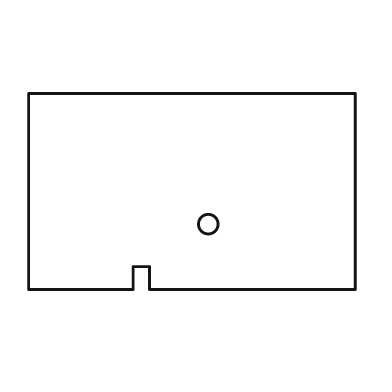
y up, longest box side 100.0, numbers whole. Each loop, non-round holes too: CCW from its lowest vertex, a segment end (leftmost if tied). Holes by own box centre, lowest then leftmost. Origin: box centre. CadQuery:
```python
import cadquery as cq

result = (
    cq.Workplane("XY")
    .moveTo(-50.0, -30.0)
    .lineTo(-18.0, -30.0)
    .lineTo(-18.0, -23.0)
    .lineTo(-13.0, -23.0)
    .lineTo(-13.0, -30.0)
    .lineTo(50.0, -30.0)
    .lineTo(50.0, 30.0)
    .lineTo(-50.0, 30.0)
    .close()
    .moveTo(5.0, -10.0)
    .circle(3.0)
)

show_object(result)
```